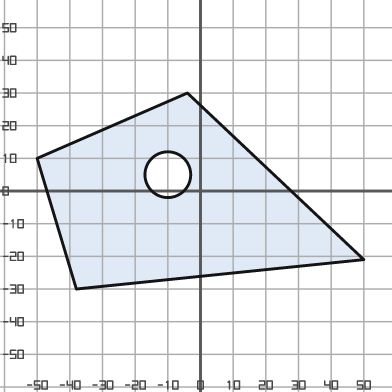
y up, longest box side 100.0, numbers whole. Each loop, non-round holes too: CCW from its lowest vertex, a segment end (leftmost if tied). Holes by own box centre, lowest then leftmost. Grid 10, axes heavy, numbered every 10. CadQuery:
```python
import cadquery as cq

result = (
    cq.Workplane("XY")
    .moveTo(-38.0, -30.0)
    .lineTo(50.0, -21.0)
    .lineTo(-4.0, 30.0)
    .lineTo(-50.0, 10.0)
    .close()
    .moveTo(-10.0, 5.0)
    .circle(7.0)
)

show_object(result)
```